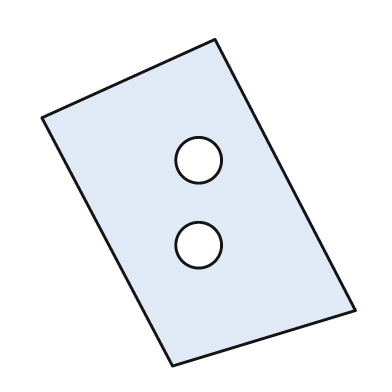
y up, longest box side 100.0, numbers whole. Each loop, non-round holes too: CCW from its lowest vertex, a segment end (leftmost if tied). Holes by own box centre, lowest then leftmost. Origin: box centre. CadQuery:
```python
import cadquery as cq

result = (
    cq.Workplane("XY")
    .moveTo(-8.0, -50.0)
    .lineTo(48.0, -33.0)
    .lineTo(5.0, 50.0)
    .lineTo(-48.0, 26.0)
    .close()
    .moveTo(0.0, -13.0)
    .circle(7.0)
    .moveTo(0.0, 13.0)
    .circle(7.0)
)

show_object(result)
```